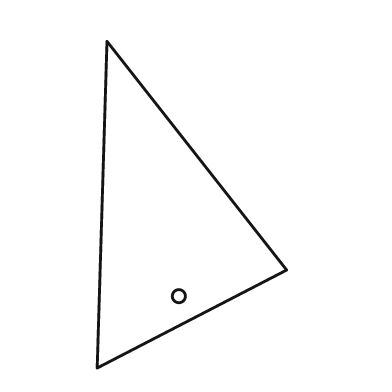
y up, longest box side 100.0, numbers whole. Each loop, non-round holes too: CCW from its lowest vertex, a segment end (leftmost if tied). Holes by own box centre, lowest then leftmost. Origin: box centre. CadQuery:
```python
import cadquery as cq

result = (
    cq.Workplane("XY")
    .moveTo(-29.0, -50.0)
    .lineTo(29.0, -20.0)
    .lineTo(-26.0, 50.0)
    .close()
    .moveTo(-4.0, -28.0)
    .circle(2.0)
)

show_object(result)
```